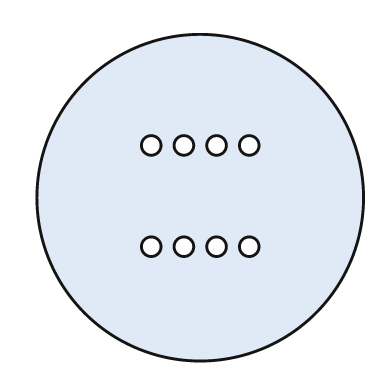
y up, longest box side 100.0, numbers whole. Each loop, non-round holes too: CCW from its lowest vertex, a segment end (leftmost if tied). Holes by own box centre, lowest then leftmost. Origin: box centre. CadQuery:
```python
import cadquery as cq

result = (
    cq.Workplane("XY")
    .moveTo(0.0, 0.0)
    .circle(50.0)
    .moveTo(-15.0, -15.0)
    .circle(3.0)
    .moveTo(-5.0, -15.0)
    .circle(3.0)
    .moveTo(5.0, -15.0)
    .circle(3.0)
    .moveTo(15.0, -15.0)
    .circle(3.0)
    .moveTo(-15.0, 16.0)
    .circle(3.0)
    .moveTo(-5.0, 16.0)
    .circle(3.0)
    .moveTo(5.0, 16.0)
    .circle(3.0)
    .moveTo(15.0, 16.0)
    .circle(3.0)
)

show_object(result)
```